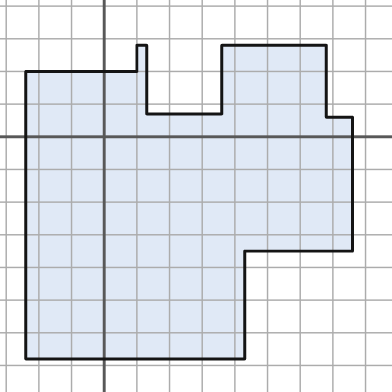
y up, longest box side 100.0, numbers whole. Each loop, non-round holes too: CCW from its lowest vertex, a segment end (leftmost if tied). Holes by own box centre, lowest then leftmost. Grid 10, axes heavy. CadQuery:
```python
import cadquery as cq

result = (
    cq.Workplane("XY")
    .moveTo(-24.0, -68.0)
    .lineTo(43.0, -68.0)
    .lineTo(43.0, -35.0)
    .lineTo(76.0, -35.0)
    .lineTo(76.0, 6.0)
    .lineTo(68.0, 6.0)
    .lineTo(68.0, 28.0)
    .lineTo(36.0, 28.0)
    .lineTo(36.0, 7.0)
    .lineTo(13.0, 7.0)
    .lineTo(13.0, 28.0)
    .lineTo(10.0, 28.0)
    .lineTo(10.0, 20.0)
    .lineTo(-24.0, 20.0)
    .close()
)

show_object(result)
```